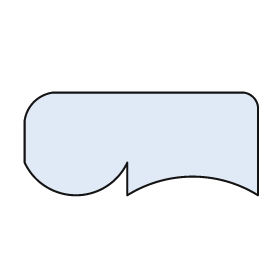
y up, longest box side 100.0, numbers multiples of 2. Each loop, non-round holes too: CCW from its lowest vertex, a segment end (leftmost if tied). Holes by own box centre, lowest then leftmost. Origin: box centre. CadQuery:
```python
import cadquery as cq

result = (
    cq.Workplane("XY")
    .moveTo(-6.0, -22.0)
    .threePointArc((22.0, -14.0), (50.0, -22.0))
    .lineTo(50.0, 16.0)
    .threePointArc((48.0, 20.0), (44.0, 22.0))
    .lineTo(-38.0, 22.0)
    .threePointArc((-46.0, 18.0), (-50.0, 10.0))
    .lineTo(-50.0, -8.0)
    .threePointArc((-28.0, -22.0), (-6.0, -8.0))
    .close()
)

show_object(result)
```